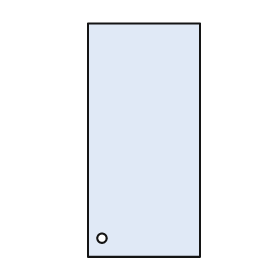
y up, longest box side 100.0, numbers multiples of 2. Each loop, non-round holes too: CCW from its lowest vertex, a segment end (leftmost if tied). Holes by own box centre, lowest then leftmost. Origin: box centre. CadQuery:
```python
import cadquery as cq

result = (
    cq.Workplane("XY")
    .moveTo(-24.0, -50.0)
    .lineTo(24.0, -50.0)
    .lineTo(24.0, 50.0)
    .lineTo(-24.0, 50.0)
    .close()
    .moveTo(-18.0, -42.0)
    .circle(2.0)
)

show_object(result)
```